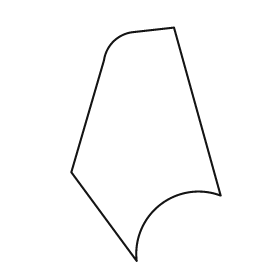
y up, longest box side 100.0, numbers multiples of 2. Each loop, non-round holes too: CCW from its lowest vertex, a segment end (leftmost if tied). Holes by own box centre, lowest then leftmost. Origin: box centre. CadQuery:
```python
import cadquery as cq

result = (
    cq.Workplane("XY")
    .moveTo(-4.0, -50.0)
    .threePointArc((6.0, -26.0), (32.0, -22.0))
    .lineTo(12.0, 50.0)
    .lineTo(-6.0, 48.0)
    .threePointArc((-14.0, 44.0), (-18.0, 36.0))
    .lineTo(-32.0, -12.0)
    .close()
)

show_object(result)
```